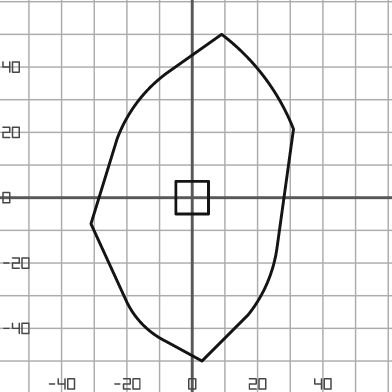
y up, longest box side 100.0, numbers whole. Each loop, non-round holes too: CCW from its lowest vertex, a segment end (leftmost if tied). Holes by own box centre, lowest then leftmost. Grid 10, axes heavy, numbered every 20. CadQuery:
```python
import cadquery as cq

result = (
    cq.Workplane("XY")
    .moveTo(3.0, -50.0)
    .lineTo(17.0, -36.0)
    .threePointArc((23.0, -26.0), (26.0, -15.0))
    .lineTo(31.0, 21.0)
    .threePointArc((22.0, 37.0), (9.0, 50.0))
    .lineTo(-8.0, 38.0)
    .threePointArc((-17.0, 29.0), (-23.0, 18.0))
    .lineTo(-31.0, -8.0)
    .lineTo(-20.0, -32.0)
    .threePointArc((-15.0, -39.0), (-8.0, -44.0))
    .close()
    .moveTo(-5.0, -5.0)
    .lineTo(5.0, -5.0)
    .lineTo(5.0, 5.0)
    .lineTo(-5.0, 5.0)
    .close()
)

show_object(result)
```